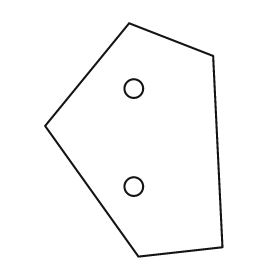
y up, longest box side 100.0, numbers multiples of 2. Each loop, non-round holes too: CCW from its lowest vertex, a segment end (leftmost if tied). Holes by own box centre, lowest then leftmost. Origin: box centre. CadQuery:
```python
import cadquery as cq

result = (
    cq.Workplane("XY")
    .moveTo(2.0, -50.0)
    .lineTo(38.0, -46.0)
    .lineTo(34.0, 36.0)
    .lineTo(-2.0, 50.0)
    .lineTo(-38.0, 6.0)
    .close()
    .moveTo(0.0, -20.0)
    .circle(4.0)
    .moveTo(0.0, 22.0)
    .circle(4.0)
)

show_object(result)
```